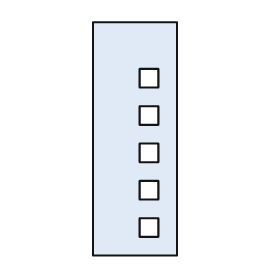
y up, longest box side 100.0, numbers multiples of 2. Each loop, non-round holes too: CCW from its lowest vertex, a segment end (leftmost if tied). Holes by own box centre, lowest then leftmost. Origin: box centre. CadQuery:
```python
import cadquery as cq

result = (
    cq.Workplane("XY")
    .moveTo(-18.0, -50.0)
    .lineTo(18.0, -50.0)
    .lineTo(18.0, 50.0)
    .lineTo(-18.0, 50.0)
    .close()
    .moveTo(2.0, -42.0)
    .lineTo(10.0, -42.0)
    .lineTo(10.0, -34.0)
    .lineTo(2.0, -34.0)
    .close()
    .moveTo(2.0, -26.0)
    .lineTo(10.0, -26.0)
    .lineTo(10.0, -18.0)
    .lineTo(2.0, -18.0)
    .close()
    .moveTo(2.0, -10.0)
    .lineTo(10.0, -10.0)
    .lineTo(10.0, -2.0)
    .lineTo(2.0, -2.0)
    .close()
    .moveTo(2.0, 6.0)
    .lineTo(10.0, 6.0)
    .lineTo(10.0, 14.0)
    .lineTo(2.0, 14.0)
    .close()
    .moveTo(2.0, 22.0)
    .lineTo(10.0, 22.0)
    .lineTo(10.0, 30.0)
    .lineTo(2.0, 30.0)
    .close()
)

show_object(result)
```